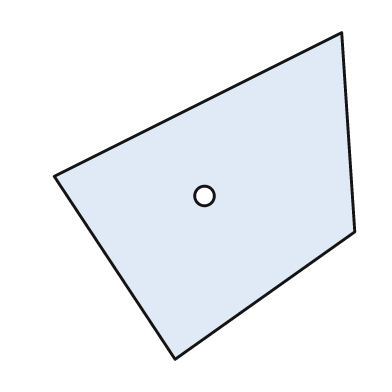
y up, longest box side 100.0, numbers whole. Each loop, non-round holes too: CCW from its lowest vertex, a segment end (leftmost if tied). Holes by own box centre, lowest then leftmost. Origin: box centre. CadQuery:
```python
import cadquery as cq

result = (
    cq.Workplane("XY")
    .moveTo(-9.0, -50.0)
    .lineTo(46.0, -11.0)
    .lineTo(42.0, 50.0)
    .lineTo(-46.0, 6.0)
    .close()
    .moveTo(0.0, 0.0)
    .circle(3.0)
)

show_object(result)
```